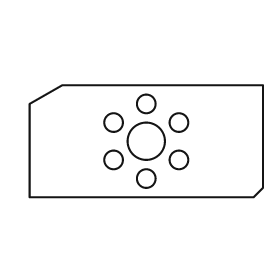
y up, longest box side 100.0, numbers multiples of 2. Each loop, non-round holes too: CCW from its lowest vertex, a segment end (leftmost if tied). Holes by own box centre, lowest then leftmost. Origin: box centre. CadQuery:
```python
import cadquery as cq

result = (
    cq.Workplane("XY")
    .moveTo(-50.0, -24.0)
    .lineTo(46.0, -24.0)
    .lineTo(50.0, -20.0)
    .lineTo(50.0, 24.0)
    .lineTo(-36.0, 24.0)
    .lineTo(-50.0, 16.0)
    .close()
    .moveTo(0.0, -16.0)
    .circle(4.0)
    .moveTo(-14.0, -8.0)
    .circle(4.0)
    .moveTo(14.0, -8.0)
    .circle(4.0)
    .moveTo(0.0, 0.0)
    .circle(8.0)
    .moveTo(-14.0, 8.0)
    .circle(4.0)
    .moveTo(14.0, 8.0)
    .circle(4.0)
    .moveTo(0.0, 16.0)
    .circle(4.0)
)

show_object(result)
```